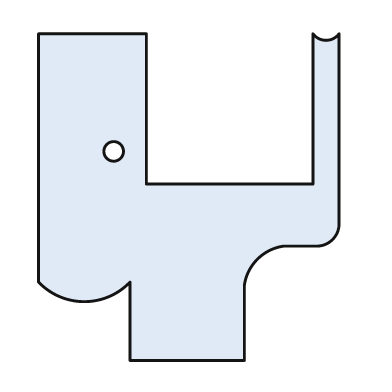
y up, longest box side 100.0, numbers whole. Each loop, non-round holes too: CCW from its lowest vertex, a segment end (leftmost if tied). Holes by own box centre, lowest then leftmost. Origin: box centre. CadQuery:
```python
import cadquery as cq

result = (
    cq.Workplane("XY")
    .moveTo(-18.0, -50.0)
    .lineTo(17.0, -50.0)
    .lineTo(17.0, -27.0)
    .threePointArc((21.0, -19.0), (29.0, -15.0))
    .lineTo(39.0, -15.0)
    .threePointArc((44.0, -13.0), (46.0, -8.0))
    .lineTo(46.0, 50.0)
    .threePointArc((42.0, 48.0), (38.0, 50.0))
    .lineTo(38.0, 4.0)
    .lineTo(-13.0, 4.0)
    .lineTo(-13.0, 50.0)
    .lineTo(-46.0, 50.0)
    .lineTo(-46.0, -26.0)
    .threePointArc((-32.0, -32.0), (-18.0, -26.0))
    .close()
    .moveTo(-23.0, 14.0)
    .circle(3.0)
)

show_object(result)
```